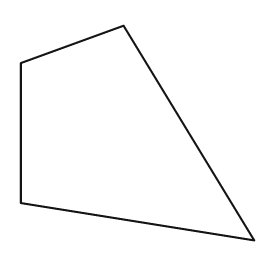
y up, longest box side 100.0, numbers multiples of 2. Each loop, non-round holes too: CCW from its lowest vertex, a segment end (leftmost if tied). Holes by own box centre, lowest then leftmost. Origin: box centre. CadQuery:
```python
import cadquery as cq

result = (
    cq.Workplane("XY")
    .moveTo(50.0, -46.0)
    .lineTo(-6.0, 46.0)
    .lineTo(-50.0, 30.0)
    .lineTo(-50.0, -30.0)
    .close()
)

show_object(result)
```